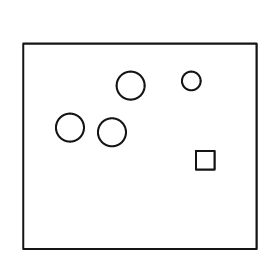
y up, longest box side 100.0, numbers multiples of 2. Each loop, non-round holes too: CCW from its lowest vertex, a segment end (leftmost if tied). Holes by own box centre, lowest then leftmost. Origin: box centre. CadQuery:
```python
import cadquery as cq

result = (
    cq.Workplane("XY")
    .moveTo(-50.0, -44.0)
    .lineTo(50.0, -44.0)
    .lineTo(50.0, 44.0)
    .lineTo(-50.0, 44.0)
    .close()
    .moveTo(24.0, -10.0)
    .lineTo(32.0, -10.0)
    .lineTo(32.0, -2.0)
    .lineTo(24.0, -2.0)
    .close()
    .moveTo(-12.0, 6.0)
    .circle(6.0)
    .moveTo(-30.0, 8.0)
    .circle(6.0)
    .moveTo(-4.0, 26.0)
    .circle(6.0)
    .moveTo(22.0, 28.0)
    .circle(4.0)
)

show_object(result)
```